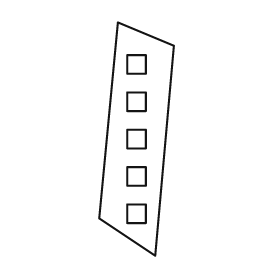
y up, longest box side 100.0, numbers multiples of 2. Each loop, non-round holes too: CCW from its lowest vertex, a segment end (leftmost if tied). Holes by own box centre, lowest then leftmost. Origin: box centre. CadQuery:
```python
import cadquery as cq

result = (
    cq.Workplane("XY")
    .moveTo(8.0, -50.0)
    .lineTo(16.0, 40.0)
    .lineTo(-8.0, 50.0)
    .lineTo(-16.0, -34.0)
    .close()
    .moveTo(-4.0, -36.0)
    .lineTo(4.0, -36.0)
    .lineTo(4.0, -28.0)
    .lineTo(-4.0, -28.0)
    .close()
    .moveTo(-4.0, -20.0)
    .lineTo(4.0, -20.0)
    .lineTo(4.0, -12.0)
    .lineTo(-4.0, -12.0)
    .close()
    .moveTo(-4.0, -4.0)
    .lineTo(4.0, -4.0)
    .lineTo(4.0, 4.0)
    .lineTo(-4.0, 4.0)
    .close()
    .moveTo(-4.0, 12.0)
    .lineTo(4.0, 12.0)
    .lineTo(4.0, 20.0)
    .lineTo(-4.0, 20.0)
    .close()
    .moveTo(-4.0, 28.0)
    .lineTo(4.0, 28.0)
    .lineTo(4.0, 36.0)
    .lineTo(-4.0, 36.0)
    .close()
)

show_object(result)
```